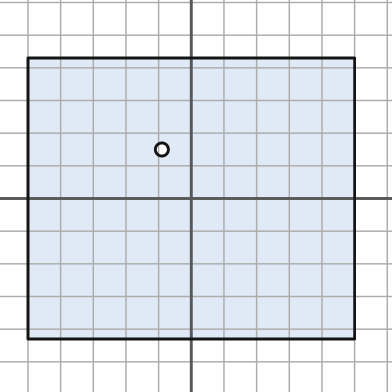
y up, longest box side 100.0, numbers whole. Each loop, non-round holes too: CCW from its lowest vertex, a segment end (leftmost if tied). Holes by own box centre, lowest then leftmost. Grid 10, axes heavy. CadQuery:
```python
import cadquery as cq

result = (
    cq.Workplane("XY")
    .moveTo(-50.0, -43.0)
    .lineTo(50.0, -43.0)
    .lineTo(50.0, 43.0)
    .lineTo(-50.0, 43.0)
    .close()
    .moveTo(-9.0, 15.0)
    .circle(2.0)
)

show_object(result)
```